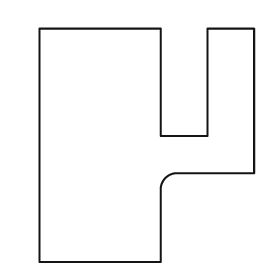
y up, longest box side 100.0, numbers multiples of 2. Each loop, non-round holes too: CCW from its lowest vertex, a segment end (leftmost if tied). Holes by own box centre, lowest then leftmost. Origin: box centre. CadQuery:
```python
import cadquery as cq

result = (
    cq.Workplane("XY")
    .moveTo(-46.0, -50.0)
    .lineTo(6.0, -50.0)
    .lineTo(6.0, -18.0)
    .threePointArc((8.0, -14.0), (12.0, -12.0))
    .lineTo(46.0, -12.0)
    .lineTo(46.0, 50.0)
    .lineTo(26.0, 50.0)
    .lineTo(26.0, 4.0)
    .lineTo(6.0, 4.0)
    .lineTo(6.0, 50.0)
    .lineTo(-46.0, 50.0)
    .close()
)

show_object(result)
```